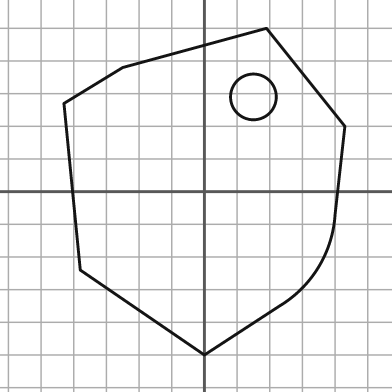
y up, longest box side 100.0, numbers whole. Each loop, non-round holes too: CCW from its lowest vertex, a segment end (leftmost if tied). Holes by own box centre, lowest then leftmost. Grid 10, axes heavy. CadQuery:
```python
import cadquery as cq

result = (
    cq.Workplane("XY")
    .moveTo(0.0, -50.0)
    .lineTo(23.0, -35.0)
    .threePointArc((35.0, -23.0), (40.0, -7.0))
    .lineTo(43.0, 20.0)
    .lineTo(19.0, 50.0)
    .lineTo(-25.0, 38.0)
    .lineTo(-43.0, 27.0)
    .lineTo(-38.0, -24.0)
    .close()
    .moveTo(15.0, 29.0)
    .circle(7.0)
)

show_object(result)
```